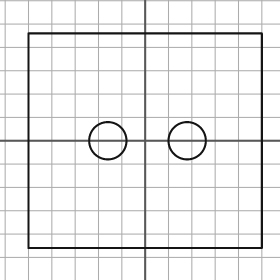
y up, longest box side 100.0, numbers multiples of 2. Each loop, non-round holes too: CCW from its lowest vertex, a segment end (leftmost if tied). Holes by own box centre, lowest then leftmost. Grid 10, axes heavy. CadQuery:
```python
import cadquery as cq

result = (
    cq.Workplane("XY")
    .moveTo(-50.0, -46.0)
    .lineTo(50.0, -46.0)
    .lineTo(50.0, 46.0)
    .lineTo(-50.0, 46.0)
    .close()
    .moveTo(-16.0, 0.0)
    .circle(8.0)
    .moveTo(18.0, 0.0)
    .circle(8.0)
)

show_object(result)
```